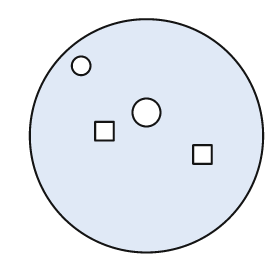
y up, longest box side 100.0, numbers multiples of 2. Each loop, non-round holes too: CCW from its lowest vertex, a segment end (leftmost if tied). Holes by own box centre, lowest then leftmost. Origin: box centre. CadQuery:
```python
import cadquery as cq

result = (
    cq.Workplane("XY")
    .moveTo(0.0, 0.0)
    .circle(50.0)
    .moveTo(20.0, -12.0)
    .lineTo(28.0, -12.0)
    .lineTo(28.0, -4.0)
    .lineTo(20.0, -4.0)
    .close()
    .moveTo(-22.0, -2.0)
    .lineTo(-14.0, -2.0)
    .lineTo(-14.0, 6.0)
    .lineTo(-22.0, 6.0)
    .close()
    .moveTo(0.0, 10.0)
    .circle(6.0)
    .moveTo(-28.0, 30.0)
    .circle(4.0)
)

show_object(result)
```